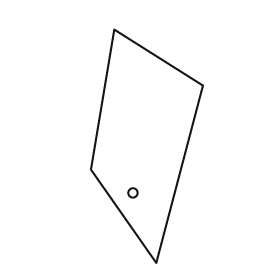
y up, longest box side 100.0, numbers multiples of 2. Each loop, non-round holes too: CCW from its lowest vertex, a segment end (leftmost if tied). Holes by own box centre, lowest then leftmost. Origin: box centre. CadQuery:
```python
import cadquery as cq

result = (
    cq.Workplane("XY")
    .moveTo(4.0, -50.0)
    .lineTo(24.0, 26.0)
    .lineTo(-14.0, 50.0)
    .lineTo(-24.0, -10.0)
    .close()
    .moveTo(-6.0, -20.0)
    .circle(2.0)
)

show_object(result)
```